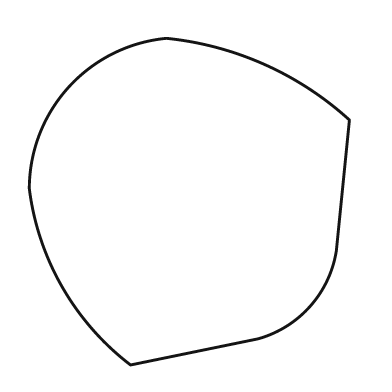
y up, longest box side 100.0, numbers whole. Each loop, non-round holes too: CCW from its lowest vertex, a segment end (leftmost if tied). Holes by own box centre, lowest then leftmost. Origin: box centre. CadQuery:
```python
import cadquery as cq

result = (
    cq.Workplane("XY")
    .moveTo(-18.0, -50.0)
    .lineTo(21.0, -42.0)
    .threePointArc((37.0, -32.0), (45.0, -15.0))
    .lineTo(49.0, 25.0)
    .threePointArc((23.0, 42.0), (-7.0, 50.0))
    .threePointArc((-37.0, 35.0), (-49.0, 4.0))
    .threePointArc((-39.0, -26.0), (-18.0, -50.0))
    .close()
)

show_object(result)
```